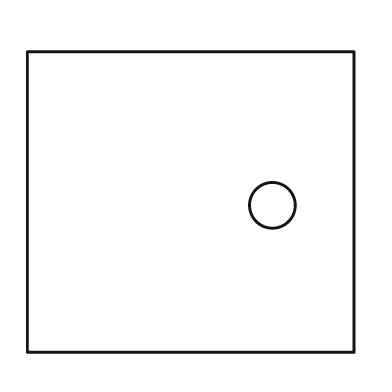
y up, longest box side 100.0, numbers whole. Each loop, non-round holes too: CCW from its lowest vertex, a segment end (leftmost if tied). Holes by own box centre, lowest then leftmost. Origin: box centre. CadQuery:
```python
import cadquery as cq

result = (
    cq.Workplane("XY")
    .moveTo(-50.0, -46.0)
    .lineTo(50.0, -46.0)
    .lineTo(50.0, 46.0)
    .lineTo(-50.0, 46.0)
    .close()
    .moveTo(25.0, -1.0)
    .circle(7.0)
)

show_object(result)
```